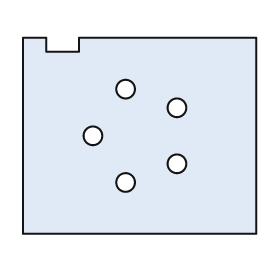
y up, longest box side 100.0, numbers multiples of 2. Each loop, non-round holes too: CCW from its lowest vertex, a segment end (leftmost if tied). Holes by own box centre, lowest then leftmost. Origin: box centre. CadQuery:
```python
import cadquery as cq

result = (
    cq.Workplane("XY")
    .moveTo(-50.0, -42.0)
    .lineTo(50.0, -42.0)
    .lineTo(50.0, 42.0)
    .lineTo(-26.0, 42.0)
    .lineTo(-26.0, 36.0)
    .lineTo(-40.0, 36.0)
    .lineTo(-40.0, 42.0)
    .lineTo(-50.0, 42.0)
    .close()
    .moveTo(-6.0, -20.0)
    .circle(4.0)
    .moveTo(16.0, -12.0)
    .circle(4.0)
    .moveTo(-20.0, 0.0)
    .circle(4.0)
    .moveTo(16.0, 12.0)
    .circle(4.0)
    .moveTo(-6.0, 20.0)
    .circle(4.0)
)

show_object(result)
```